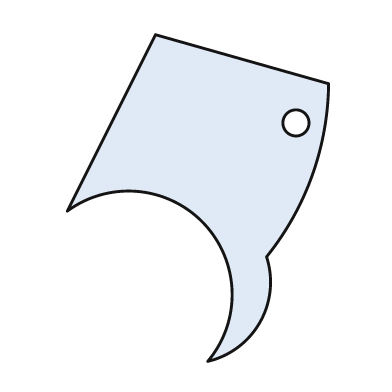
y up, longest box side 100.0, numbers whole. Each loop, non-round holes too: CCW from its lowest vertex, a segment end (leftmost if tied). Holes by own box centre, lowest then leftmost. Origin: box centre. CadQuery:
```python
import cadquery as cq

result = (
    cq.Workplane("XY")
    .moveTo(3.0, -50.0)
    .threePointArc((19.0, -38.0), (21.0, -18.0))
    .threePointArc((35.0, 7.0), (40.0, 35.0))
    .lineTo(-13.0, 50.0)
    .lineTo(-40.0, -4.0)
    .threePointArc((2.0, -8.0), (3.0, -50.0))
    .close()
    .moveTo(30.0, 23.0)
    .circle(4.0)
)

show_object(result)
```